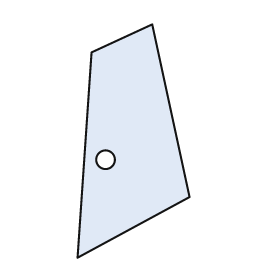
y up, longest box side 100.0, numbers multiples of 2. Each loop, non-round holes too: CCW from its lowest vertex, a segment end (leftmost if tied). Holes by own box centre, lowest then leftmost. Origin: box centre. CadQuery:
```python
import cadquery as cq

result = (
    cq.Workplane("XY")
    .moveTo(-24.0, -50.0)
    .lineTo(24.0, -24.0)
    .lineTo(8.0, 50.0)
    .lineTo(-18.0, 38.0)
    .close()
    .moveTo(-12.0, -8.0)
    .circle(4.0)
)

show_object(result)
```